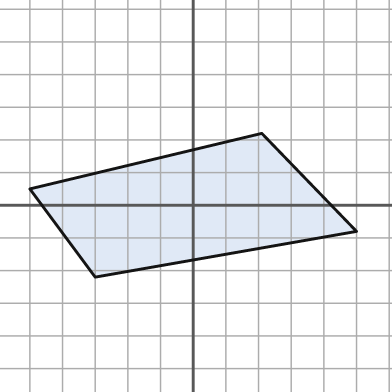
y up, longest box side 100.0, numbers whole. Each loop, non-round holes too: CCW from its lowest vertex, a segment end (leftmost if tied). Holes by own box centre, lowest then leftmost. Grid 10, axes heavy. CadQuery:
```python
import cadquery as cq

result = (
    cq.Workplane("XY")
    .moveTo(-30.0, -22.0)
    .lineTo(50.0, -8.0)
    .lineTo(21.0, 22.0)
    .lineTo(-50.0, 5.0)
    .close()
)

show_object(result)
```